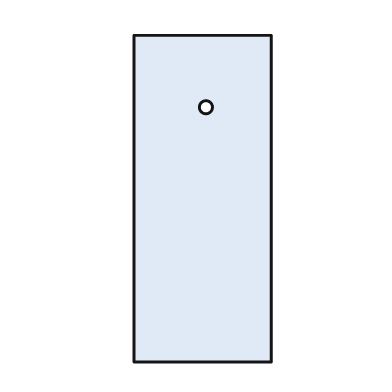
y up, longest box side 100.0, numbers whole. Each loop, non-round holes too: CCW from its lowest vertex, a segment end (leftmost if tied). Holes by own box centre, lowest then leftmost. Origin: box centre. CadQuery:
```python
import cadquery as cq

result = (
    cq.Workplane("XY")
    .moveTo(-21.0, -50.0)
    .lineTo(21.0, -50.0)
    .lineTo(21.0, 50.0)
    .lineTo(-21.0, 50.0)
    .close()
    .moveTo(1.0, 28.0)
    .circle(2.0)
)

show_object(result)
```